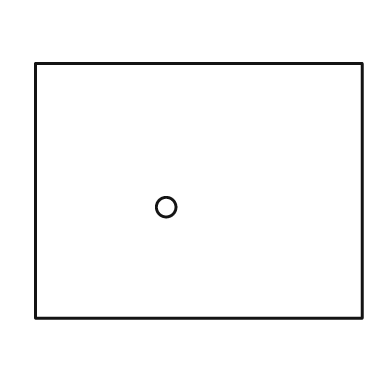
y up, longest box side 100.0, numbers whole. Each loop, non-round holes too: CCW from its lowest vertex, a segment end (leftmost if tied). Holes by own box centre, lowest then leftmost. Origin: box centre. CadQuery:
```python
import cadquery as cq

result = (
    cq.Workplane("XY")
    .moveTo(-50.0, -39.0)
    .lineTo(50.0, -39.0)
    .lineTo(50.0, 39.0)
    .lineTo(-50.0, 39.0)
    .close()
    .moveTo(-10.0, -5.0)
    .circle(3.0)
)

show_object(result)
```